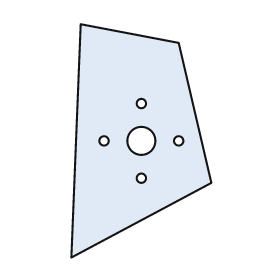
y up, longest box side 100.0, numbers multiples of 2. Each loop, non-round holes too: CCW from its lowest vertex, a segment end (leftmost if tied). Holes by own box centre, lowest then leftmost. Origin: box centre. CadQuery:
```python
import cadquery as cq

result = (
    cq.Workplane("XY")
    .moveTo(-30.0, -50.0)
    .lineTo(30.0, -18.0)
    .lineTo(16.0, 42.0)
    .lineTo(-26.0, 50.0)
    .close()
    .moveTo(0.0, -16.0)
    .circle(2.0)
    .moveTo(-16.0, 0.0)
    .circle(2.0)
    .moveTo(0.0, 0.0)
    .circle(6.0)
    .moveTo(16.0, 0.0)
    .circle(2.0)
    .moveTo(0.0, 16.0)
    .circle(2.0)
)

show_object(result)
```